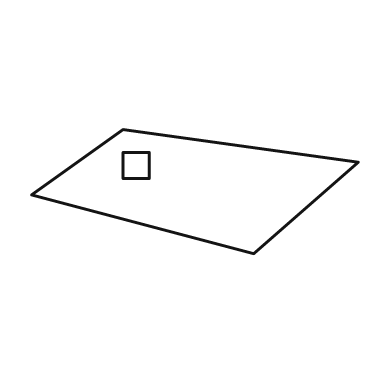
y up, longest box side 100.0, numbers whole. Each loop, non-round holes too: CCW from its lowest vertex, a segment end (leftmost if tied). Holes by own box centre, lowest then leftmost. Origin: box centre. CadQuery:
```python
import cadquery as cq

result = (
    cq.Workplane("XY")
    .moveTo(18.0, -19.0)
    .lineTo(50.0, 9.0)
    .lineTo(-22.0, 19.0)
    .lineTo(-50.0, -1.0)
    .close()
    .moveTo(-22.0, 4.0)
    .lineTo(-14.0, 4.0)
    .lineTo(-14.0, 12.0)
    .lineTo(-22.0, 12.0)
    .close()
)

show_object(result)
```